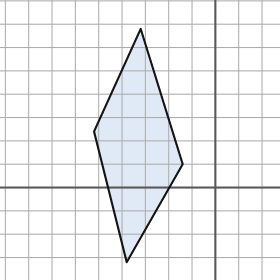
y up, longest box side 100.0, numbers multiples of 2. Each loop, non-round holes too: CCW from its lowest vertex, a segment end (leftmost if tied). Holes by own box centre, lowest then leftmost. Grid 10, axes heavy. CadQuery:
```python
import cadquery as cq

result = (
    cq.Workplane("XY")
    .moveTo(-38.0, -32.0)
    .lineTo(-14.0, 10.0)
    .lineTo(-32.0, 68.0)
    .lineTo(-52.0, 24.0)
    .close()
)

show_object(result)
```